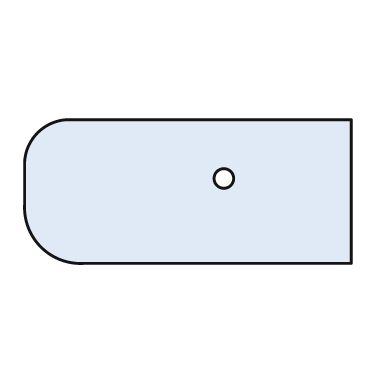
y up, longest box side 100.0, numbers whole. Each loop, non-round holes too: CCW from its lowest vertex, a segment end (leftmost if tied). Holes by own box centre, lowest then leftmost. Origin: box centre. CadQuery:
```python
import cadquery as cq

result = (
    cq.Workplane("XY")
    .moveTo(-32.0, -22.0)
    .lineTo(50.0, -22.0)
    .lineTo(50.0, 22.0)
    .lineTo(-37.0, 22.0)
    .threePointArc((-46.0, 18.0), (-50.0, 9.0))
    .lineTo(-50.0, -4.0)
    .threePointArc((-45.0, -17.0), (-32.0, -22.0))
    .close()
    .moveTo(11.0, 4.0)
    .circle(3.0)
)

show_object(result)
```